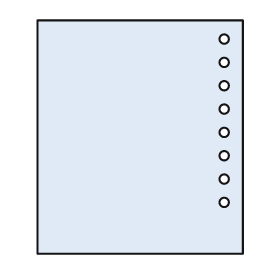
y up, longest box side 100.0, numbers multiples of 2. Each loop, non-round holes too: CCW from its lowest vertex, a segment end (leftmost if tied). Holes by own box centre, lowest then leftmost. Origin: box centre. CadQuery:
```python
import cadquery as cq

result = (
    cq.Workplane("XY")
    .moveTo(-44.0, -50.0)
    .lineTo(44.0, -50.0)
    .lineTo(44.0, 50.0)
    .lineTo(-44.0, 50.0)
    .close()
    .moveTo(36.0, -28.0)
    .circle(2.0)
    .moveTo(36.0, -18.0)
    .circle(2.0)
    .moveTo(36.0, -8.0)
    .circle(2.0)
    .moveTo(36.0, 2.0)
    .circle(2.0)
    .moveTo(36.0, 12.0)
    .circle(2.0)
    .moveTo(36.0, 22.0)
    .circle(2.0)
    .moveTo(36.0, 32.0)
    .circle(2.0)
    .moveTo(36.0, 42.0)
    .circle(2.0)
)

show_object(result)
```